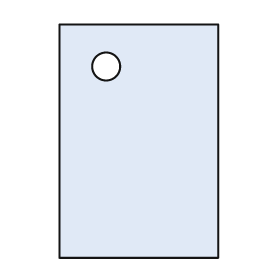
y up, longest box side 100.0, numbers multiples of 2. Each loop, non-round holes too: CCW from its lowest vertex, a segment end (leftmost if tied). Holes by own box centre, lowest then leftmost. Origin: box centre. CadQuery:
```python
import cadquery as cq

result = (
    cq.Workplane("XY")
    .moveTo(-34.0, -50.0)
    .lineTo(34.0, -50.0)
    .lineTo(34.0, 50.0)
    .lineTo(-34.0, 50.0)
    .close()
    .moveTo(-14.0, 32.0)
    .circle(6.0)
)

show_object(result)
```